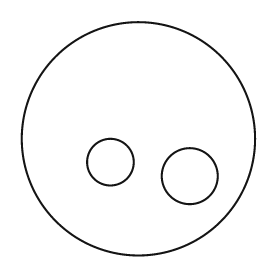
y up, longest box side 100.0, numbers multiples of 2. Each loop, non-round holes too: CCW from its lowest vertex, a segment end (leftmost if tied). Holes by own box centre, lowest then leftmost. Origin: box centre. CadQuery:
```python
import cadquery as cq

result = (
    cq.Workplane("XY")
    .moveTo(0.0, 0.0)
    .circle(50.0)
    .moveTo(22.0, -16.0)
    .circle(12.0)
    .moveTo(-12.0, -10.0)
    .circle(10.0)
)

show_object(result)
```